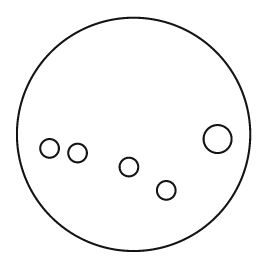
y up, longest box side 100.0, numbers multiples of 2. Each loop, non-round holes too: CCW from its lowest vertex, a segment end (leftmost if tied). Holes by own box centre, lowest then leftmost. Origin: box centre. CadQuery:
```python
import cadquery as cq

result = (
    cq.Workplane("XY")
    .moveTo(0.0, 0.0)
    .circle(50.0)
    .moveTo(14.0, -24.0)
    .circle(4.0)
    .moveTo(-2.0, -14.0)
    .circle(4.0)
    .moveTo(-24.0, -8.0)
    .circle(4.0)
    .moveTo(-36.0, -6.0)
    .circle(4.0)
    .moveTo(36.0, -2.0)
    .circle(6.0)
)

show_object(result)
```